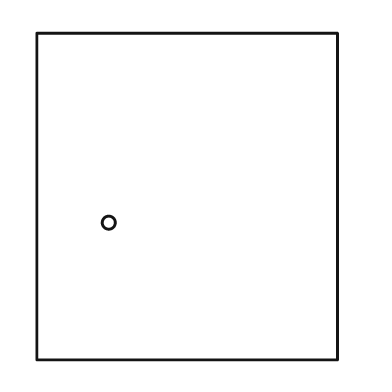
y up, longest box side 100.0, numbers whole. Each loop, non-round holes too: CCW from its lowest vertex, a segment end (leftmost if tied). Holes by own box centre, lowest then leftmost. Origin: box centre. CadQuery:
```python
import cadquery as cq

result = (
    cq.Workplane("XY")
    .moveTo(-46.0, -50.0)
    .lineTo(46.0, -50.0)
    .lineTo(46.0, 50.0)
    .lineTo(-46.0, 50.0)
    .close()
    .moveTo(-24.0, -8.0)
    .circle(2.0)
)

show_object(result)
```